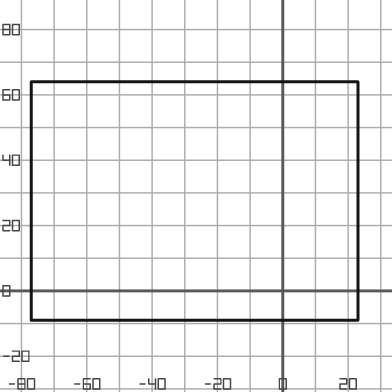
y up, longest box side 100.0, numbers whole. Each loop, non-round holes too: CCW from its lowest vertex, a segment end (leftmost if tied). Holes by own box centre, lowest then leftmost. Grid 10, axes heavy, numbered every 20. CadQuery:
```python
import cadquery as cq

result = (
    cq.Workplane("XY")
    .moveTo(-77.0, -9.0)
    .lineTo(23.0, -9.0)
    .lineTo(23.0, 64.0)
    .lineTo(-77.0, 64.0)
    .close()
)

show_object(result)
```